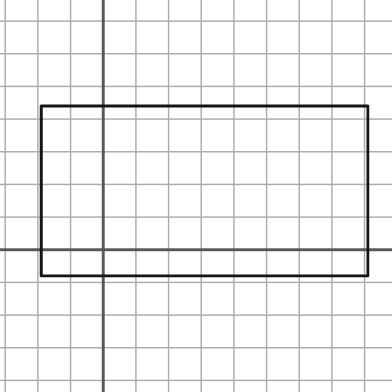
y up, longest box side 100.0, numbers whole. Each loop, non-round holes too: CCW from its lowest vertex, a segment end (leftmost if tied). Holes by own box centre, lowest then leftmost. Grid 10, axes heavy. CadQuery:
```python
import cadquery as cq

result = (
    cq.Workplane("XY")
    .moveTo(-19.0, -8.0)
    .lineTo(81.0, -8.0)
    .lineTo(81.0, 44.0)
    .lineTo(-19.0, 44.0)
    .close()
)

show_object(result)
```